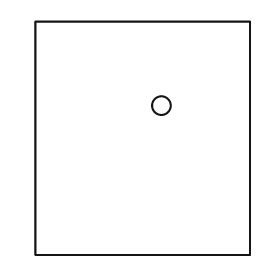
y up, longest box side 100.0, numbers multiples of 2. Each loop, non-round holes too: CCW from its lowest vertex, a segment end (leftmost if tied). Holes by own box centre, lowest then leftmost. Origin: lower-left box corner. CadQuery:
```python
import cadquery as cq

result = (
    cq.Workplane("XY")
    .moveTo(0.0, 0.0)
    .lineTo(92.0, 0.0)
    .lineTo(92.0, 100.0)
    .lineTo(0.0, 100.0)
    .close()
    .moveTo(54.0, 64.0)
    .circle(4.0)
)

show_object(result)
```